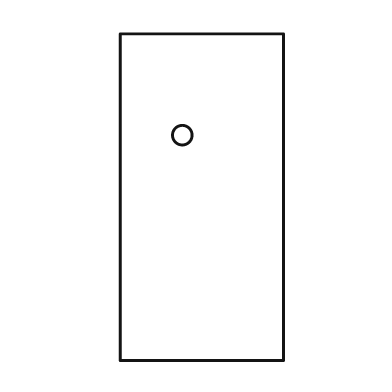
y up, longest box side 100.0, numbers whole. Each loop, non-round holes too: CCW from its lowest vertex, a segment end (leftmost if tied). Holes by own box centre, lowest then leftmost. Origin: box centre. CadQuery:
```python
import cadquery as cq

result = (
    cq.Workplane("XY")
    .moveTo(-25.0, -50.0)
    .lineTo(25.0, -50.0)
    .lineTo(25.0, 50.0)
    .lineTo(-25.0, 50.0)
    .close()
    .moveTo(-6.0, 19.0)
    .circle(3.0)
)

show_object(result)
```